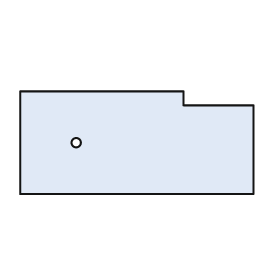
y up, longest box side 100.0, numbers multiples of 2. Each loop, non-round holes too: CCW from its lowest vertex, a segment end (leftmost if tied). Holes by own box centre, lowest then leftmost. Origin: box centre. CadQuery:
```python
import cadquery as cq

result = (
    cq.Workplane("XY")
    .moveTo(-50.0, -22.0)
    .lineTo(50.0, -22.0)
    .lineTo(50.0, 16.0)
    .lineTo(20.0, 16.0)
    .lineTo(20.0, 22.0)
    .lineTo(-50.0, 22.0)
    .close()
    .moveTo(-26.0, 0.0)
    .circle(2.0)
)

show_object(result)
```